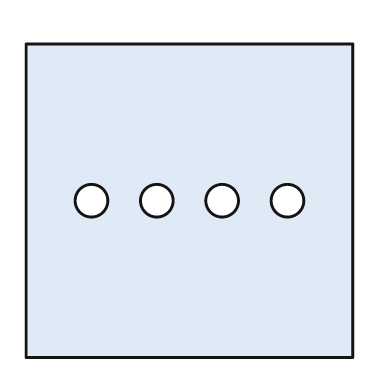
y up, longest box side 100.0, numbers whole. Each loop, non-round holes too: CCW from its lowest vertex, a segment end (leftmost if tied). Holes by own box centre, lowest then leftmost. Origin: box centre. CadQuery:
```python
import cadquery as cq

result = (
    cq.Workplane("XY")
    .moveTo(-50.0, -48.0)
    .lineTo(50.0, -48.0)
    .lineTo(50.0, 48.0)
    .lineTo(-50.0, 48.0)
    .close()
    .moveTo(-30.0, 0.0)
    .circle(5.0)
    .moveTo(-10.0, 0.0)
    .circle(5.0)
    .moveTo(10.0, 0.0)
    .circle(5.0)
    .moveTo(30.0, 0.0)
    .circle(5.0)
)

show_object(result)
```